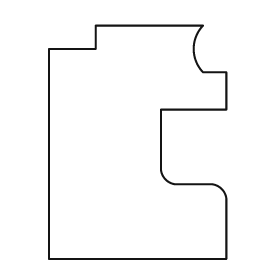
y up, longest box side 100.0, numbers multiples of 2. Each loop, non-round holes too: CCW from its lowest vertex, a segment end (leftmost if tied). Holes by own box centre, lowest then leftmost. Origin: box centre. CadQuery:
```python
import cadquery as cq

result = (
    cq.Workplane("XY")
    .moveTo(-38.0, -50.0)
    .lineTo(38.0, -50.0)
    .lineTo(38.0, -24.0)
    .threePointArc((36.0, -20.0), (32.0, -18.0))
    .lineTo(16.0, -18.0)
    .threePointArc((12.0, -16.0), (10.0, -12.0))
    .lineTo(10.0, 14.0)
    .lineTo(38.0, 14.0)
    .lineTo(38.0, 30.0)
    .lineTo(28.0, 30.0)
    .threePointArc((24.0, 40.0), (28.0, 50.0))
    .lineTo(-18.0, 50.0)
    .lineTo(-18.0, 40.0)
    .lineTo(-38.0, 40.0)
    .close()
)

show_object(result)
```